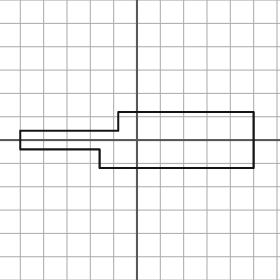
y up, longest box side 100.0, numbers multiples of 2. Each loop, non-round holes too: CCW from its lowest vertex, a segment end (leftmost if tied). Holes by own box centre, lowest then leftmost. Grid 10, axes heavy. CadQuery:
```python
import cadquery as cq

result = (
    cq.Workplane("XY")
    .moveTo(-16.0, -12.0)
    .lineTo(50.0, -12.0)
    .lineTo(50.0, 12.0)
    .lineTo(-8.0, 12.0)
    .lineTo(-8.0, 4.0)
    .lineTo(-50.0, 4.0)
    .lineTo(-50.0, -4.0)
    .lineTo(-16.0, -4.0)
    .close()
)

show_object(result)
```